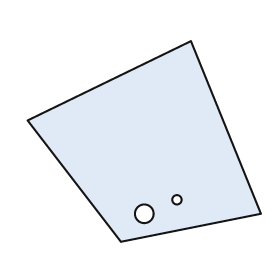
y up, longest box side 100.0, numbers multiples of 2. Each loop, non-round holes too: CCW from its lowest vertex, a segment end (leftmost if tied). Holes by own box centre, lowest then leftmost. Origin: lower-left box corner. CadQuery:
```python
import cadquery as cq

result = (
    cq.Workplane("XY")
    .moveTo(40.0, 0.0)
    .lineTo(100.0, 12.0)
    .lineTo(70.0, 86.0)
    .lineTo(0.0, 52.0)
    .close()
    .moveTo(50.0, 12.0)
    .circle(4.0)
    .moveTo(64.0, 18.0)
    .circle(2.0)
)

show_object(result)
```